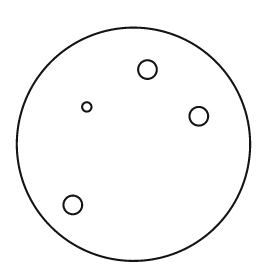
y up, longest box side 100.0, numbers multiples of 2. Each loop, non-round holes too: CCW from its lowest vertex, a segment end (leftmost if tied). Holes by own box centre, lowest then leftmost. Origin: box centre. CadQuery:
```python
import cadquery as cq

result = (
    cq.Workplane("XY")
    .moveTo(0.0, 0.0)
    .circle(50.0)
    .moveTo(-26.0, -26.0)
    .circle(4.0)
    .moveTo(28.0, 12.0)
    .circle(4.0)
    .moveTo(-20.0, 16.0)
    .circle(2.0)
    .moveTo(6.0, 32.0)
    .circle(4.0)
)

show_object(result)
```